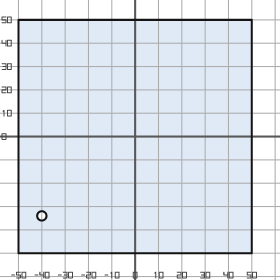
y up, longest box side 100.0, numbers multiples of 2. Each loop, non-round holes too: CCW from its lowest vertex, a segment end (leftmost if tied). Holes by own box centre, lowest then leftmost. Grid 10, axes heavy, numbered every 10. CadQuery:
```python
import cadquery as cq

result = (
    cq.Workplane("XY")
    .moveTo(-50.0, -50.0)
    .lineTo(50.0, -50.0)
    .lineTo(50.0, 50.0)
    .lineTo(-50.0, 50.0)
    .close()
    .moveTo(-40.0, -34.0)
    .circle(2.0)
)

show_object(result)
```